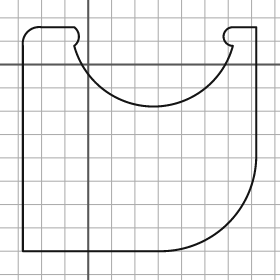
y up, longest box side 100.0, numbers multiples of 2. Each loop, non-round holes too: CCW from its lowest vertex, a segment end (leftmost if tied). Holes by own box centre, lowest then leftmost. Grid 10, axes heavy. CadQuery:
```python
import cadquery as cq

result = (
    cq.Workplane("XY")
    .moveTo(-28.0, -80.0)
    .lineTo(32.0, -80.0)
    .threePointArc((60.0, -68.0), (72.0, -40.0))
    .lineTo(72.0, 16.0)
    .lineTo(62.0, 16.0)
    .threePointArc((58.0, 12.0), (62.0, 8.0))
    .threePointArc((28.0, -18.0), (-6.0, 8.0))
    .threePointArc((-4.0, 12.0), (-6.0, 16.0))
    .lineTo(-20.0, 16.0)
    .threePointArc((-26.0, 14.0), (-28.0, 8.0))
    .close()
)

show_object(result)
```